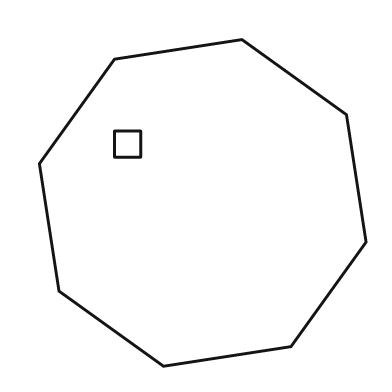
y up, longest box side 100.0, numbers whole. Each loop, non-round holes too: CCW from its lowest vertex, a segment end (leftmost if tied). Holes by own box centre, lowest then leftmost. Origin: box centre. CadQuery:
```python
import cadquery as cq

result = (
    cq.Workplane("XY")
    .moveTo(-12.0, -50.0)
    .lineTo(27.0, -44.0)
    .lineTo(50.0, -12.0)
    .lineTo(44.0, 27.0)
    .lineTo(12.0, 50.0)
    .lineTo(-27.0, 44.0)
    .lineTo(-50.0, 12.0)
    .lineTo(-44.0, -27.0)
    .close()
    .moveTo(-27.0, 14.0)
    .lineTo(-19.0, 14.0)
    .lineTo(-19.0, 22.0)
    .lineTo(-27.0, 22.0)
    .close()
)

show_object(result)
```